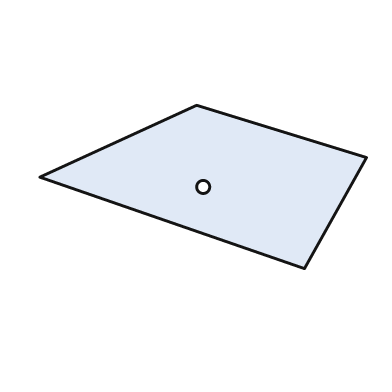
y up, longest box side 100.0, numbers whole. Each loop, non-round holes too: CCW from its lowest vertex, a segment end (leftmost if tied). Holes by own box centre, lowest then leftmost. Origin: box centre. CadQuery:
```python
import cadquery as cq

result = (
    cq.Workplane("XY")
    .moveTo(31.0, -25.0)
    .lineTo(50.0, 9.0)
    .lineTo(-2.0, 25.0)
    .lineTo(-50.0, 3.0)
    .close()
    .moveTo(0.0, 0.0)
    .circle(2.0)
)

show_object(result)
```